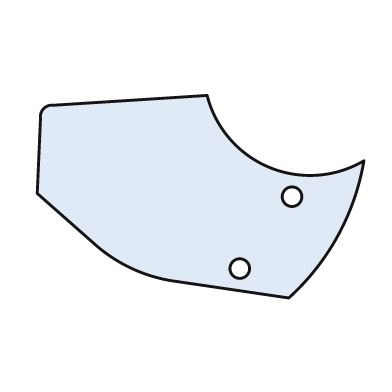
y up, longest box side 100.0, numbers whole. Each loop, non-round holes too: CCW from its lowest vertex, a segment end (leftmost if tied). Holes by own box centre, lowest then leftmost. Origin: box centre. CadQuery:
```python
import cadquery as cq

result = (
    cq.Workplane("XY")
    .moveTo(27.0, -31.0)
    .threePointArc((42.0, -12.0), (50.0, 11.0))
    .threePointArc((21.0, 9.0), (2.0, 31.0))
    .lineTo(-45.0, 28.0)
    .threePointArc((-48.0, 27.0), (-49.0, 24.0))
    .lineTo(-50.0, 1.0)
    .lineTo(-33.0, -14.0)
    .threePointArc((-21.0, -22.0), (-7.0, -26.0))
    .close()
    .moveTo(12.0, -22.0)
    .circle(3.0)
    .moveTo(28.0, 0.0)
    .circle(3.0)
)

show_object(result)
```